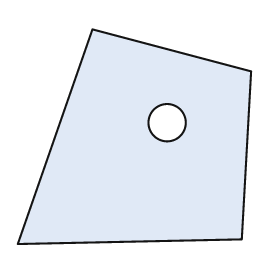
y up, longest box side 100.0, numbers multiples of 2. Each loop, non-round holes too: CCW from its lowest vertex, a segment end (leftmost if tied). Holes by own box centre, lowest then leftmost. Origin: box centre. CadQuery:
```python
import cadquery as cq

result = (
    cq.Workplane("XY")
    .moveTo(-50.0, -46.0)
    .lineTo(46.0, -44.0)
    .lineTo(50.0, 28.0)
    .lineTo(-18.0, 46.0)
    .close()
    .moveTo(14.0, 6.0)
    .circle(8.0)
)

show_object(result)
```